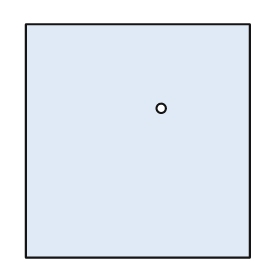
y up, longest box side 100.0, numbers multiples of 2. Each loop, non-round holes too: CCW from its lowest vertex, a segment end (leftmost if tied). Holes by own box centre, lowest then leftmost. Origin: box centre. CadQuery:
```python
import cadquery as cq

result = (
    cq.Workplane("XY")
    .moveTo(-48.0, -50.0)
    .lineTo(48.0, -50.0)
    .lineTo(48.0, 50.0)
    .lineTo(-48.0, 50.0)
    .close()
    .moveTo(10.0, 14.0)
    .circle(2.0)
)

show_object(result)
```